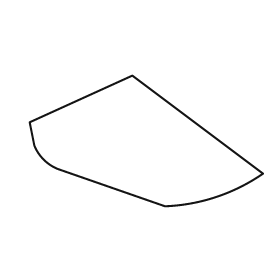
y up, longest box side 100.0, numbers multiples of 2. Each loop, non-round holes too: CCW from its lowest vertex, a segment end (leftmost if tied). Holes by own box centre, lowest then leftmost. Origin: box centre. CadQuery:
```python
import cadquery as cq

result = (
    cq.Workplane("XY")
    .moveTo(8.0, -28.0)
    .threePointArc((30.0, -24.0), (50.0, -14.0))
    .lineTo(-6.0, 28.0)
    .lineTo(-50.0, 8.0)
    .lineTo(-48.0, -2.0)
    .threePointArc((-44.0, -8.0), (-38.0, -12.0))
    .close()
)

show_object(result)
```